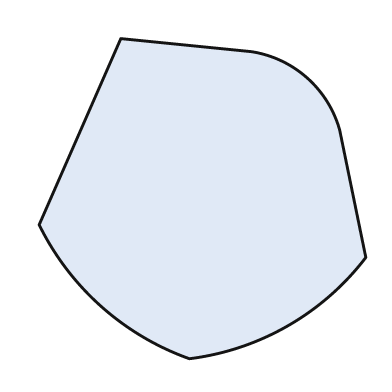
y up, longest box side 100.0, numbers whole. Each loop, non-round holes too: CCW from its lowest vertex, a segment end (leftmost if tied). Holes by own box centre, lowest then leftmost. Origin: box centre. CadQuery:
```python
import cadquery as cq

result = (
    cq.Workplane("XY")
    .moveTo(-4.0, -49.0)
    .threePointArc((26.0, -39.0), (50.0, -18.0))
    .lineTo(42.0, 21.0)
    .threePointArc((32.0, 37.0), (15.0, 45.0))
    .lineTo(-25.0, 49.0)
    .lineTo(-50.0, -8.0)
    .threePointArc((-31.0, -33.0), (-4.0, -49.0))
    .close()
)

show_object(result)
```